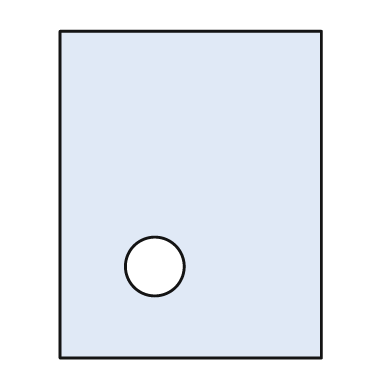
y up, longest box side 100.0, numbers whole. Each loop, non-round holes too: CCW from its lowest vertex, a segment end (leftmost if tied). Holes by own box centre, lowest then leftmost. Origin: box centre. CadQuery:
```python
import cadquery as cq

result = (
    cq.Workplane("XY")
    .moveTo(-40.0, -50.0)
    .lineTo(40.0, -50.0)
    .lineTo(40.0, 50.0)
    .lineTo(-40.0, 50.0)
    .close()
    .moveTo(-11.0, -22.0)
    .circle(9.0)
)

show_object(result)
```